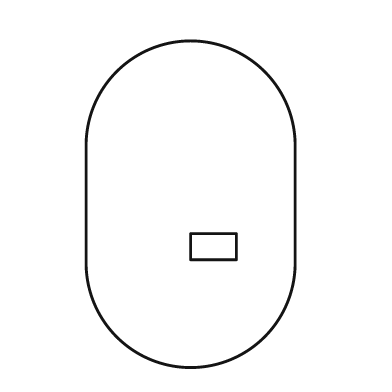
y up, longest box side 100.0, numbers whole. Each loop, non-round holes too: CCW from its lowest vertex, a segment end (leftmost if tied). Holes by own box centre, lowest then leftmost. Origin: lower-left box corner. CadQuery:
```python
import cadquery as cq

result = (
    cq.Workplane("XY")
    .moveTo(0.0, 32.0)
    .threePointArc((32.0, 0.0), (64.0, 32.0))
    .lineTo(64.0, 68.0)
    .threePointArc((32.0, 100.0), (0.0, 68.0))
    .close()
    .moveTo(32.0, 33.0)
    .lineTo(46.0, 33.0)
    .lineTo(46.0, 41.0)
    .lineTo(32.0, 41.0)
    .close()
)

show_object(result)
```